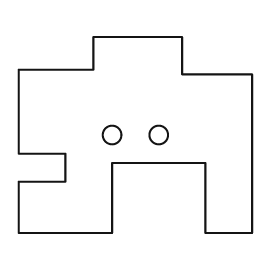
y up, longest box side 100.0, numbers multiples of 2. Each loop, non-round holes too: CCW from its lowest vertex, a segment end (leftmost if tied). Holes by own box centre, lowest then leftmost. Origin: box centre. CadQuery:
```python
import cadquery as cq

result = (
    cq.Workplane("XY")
    .moveTo(-50.0, -42.0)
    .lineTo(-10.0, -42.0)
    .lineTo(-10.0, -12.0)
    .lineTo(30.0, -12.0)
    .lineTo(30.0, -42.0)
    .lineTo(50.0, -42.0)
    .lineTo(50.0, 26.0)
    .lineTo(20.0, 26.0)
    .lineTo(20.0, 42.0)
    .lineTo(-18.0, 42.0)
    .lineTo(-18.0, 28.0)
    .lineTo(-50.0, 28.0)
    .lineTo(-50.0, -8.0)
    .lineTo(-30.0, -8.0)
    .lineTo(-30.0, -20.0)
    .lineTo(-50.0, -20.0)
    .close()
    .moveTo(-10.0, 0.0)
    .circle(4.0)
    .moveTo(10.0, 0.0)
    .circle(4.0)
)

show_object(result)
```